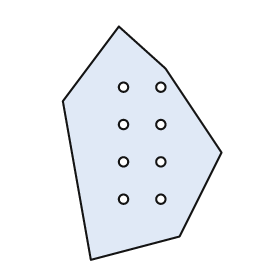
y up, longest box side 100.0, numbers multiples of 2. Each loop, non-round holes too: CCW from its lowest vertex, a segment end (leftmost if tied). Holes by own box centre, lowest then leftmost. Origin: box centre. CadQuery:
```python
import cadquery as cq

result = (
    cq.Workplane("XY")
    .moveTo(-22.0, -50.0)
    .lineTo(16.0, -40.0)
    .lineTo(34.0, -4.0)
    .lineTo(10.0, 32.0)
    .lineTo(-10.0, 50.0)
    .lineTo(-34.0, 18.0)
    .close()
    .moveTo(-8.0, -24.0)
    .circle(2.0)
    .moveTo(8.0, -24.0)
    .circle(2.0)
    .moveTo(-8.0, -8.0)
    .circle(2.0)
    .moveTo(8.0, -8.0)
    .circle(2.0)
    .moveTo(-8.0, 8.0)
    .circle(2.0)
    .moveTo(8.0, 8.0)
    .circle(2.0)
    .moveTo(-8.0, 24.0)
    .circle(2.0)
    .moveTo(8.0, 24.0)
    .circle(2.0)
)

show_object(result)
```